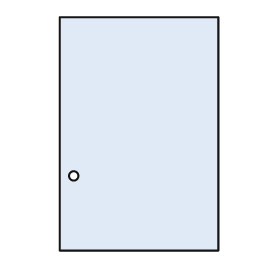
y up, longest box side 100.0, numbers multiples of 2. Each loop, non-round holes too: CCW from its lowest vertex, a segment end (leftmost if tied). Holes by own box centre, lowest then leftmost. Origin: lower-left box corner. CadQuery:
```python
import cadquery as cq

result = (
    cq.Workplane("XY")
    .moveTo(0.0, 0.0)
    .lineTo(68.0, 0.0)
    .lineTo(68.0, 100.0)
    .lineTo(0.0, 100.0)
    .close()
    .moveTo(6.0, 32.0)
    .circle(2.0)
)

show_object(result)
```